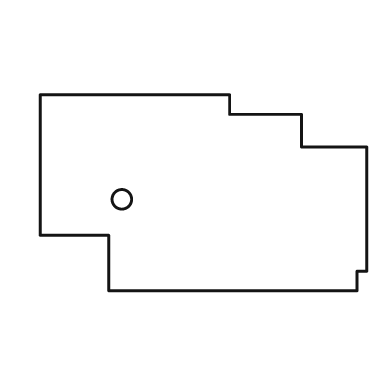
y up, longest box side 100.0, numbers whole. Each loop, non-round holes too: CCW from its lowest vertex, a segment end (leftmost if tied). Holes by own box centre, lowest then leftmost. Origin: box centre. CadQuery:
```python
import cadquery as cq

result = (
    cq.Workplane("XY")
    .moveTo(-29.0, -30.0)
    .lineTo(47.0, -30.0)
    .lineTo(47.0, -24.0)
    .lineTo(50.0, -24.0)
    .lineTo(50.0, 14.0)
    .lineTo(30.0, 14.0)
    .lineTo(30.0, 24.0)
    .lineTo(8.0, 24.0)
    .lineTo(8.0, 30.0)
    .lineTo(-50.0, 30.0)
    .lineTo(-50.0, -13.0)
    .lineTo(-29.0, -13.0)
    .close()
    .moveTo(-25.0, -2.0)
    .circle(3.0)
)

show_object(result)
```